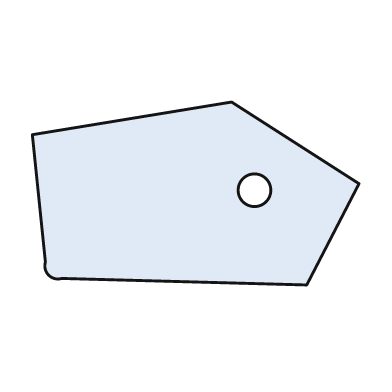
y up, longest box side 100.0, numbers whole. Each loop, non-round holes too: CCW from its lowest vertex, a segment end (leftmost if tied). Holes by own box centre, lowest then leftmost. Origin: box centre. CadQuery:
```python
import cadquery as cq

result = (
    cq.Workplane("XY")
    .moveTo(34.0, -28.0)
    .lineTo(50.0, 3.0)
    .lineTo(11.0, 28.0)
    .lineTo(-50.0, 18.0)
    .lineTo(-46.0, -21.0)
    .threePointArc((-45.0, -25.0), (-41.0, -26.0))
    .close()
    .moveTo(18.0, 1.0)
    .circle(5.0)
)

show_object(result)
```